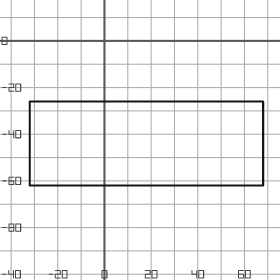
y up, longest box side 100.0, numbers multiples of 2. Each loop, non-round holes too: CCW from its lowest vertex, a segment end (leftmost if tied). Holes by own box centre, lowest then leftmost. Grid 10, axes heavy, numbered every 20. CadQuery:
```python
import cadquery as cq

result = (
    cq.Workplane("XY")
    .moveTo(-32.0, -62.0)
    .lineTo(68.0, -62.0)
    .lineTo(68.0, -26.0)
    .lineTo(-32.0, -26.0)
    .close()
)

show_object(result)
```